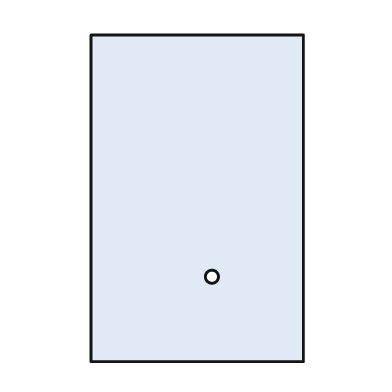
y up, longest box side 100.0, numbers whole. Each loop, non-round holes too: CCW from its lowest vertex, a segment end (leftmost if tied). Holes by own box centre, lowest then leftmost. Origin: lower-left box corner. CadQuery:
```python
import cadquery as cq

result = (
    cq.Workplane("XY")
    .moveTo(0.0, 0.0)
    .lineTo(65.0, 0.0)
    .lineTo(65.0, 100.0)
    .lineTo(0.0, 100.0)
    .close()
    .moveTo(37.0, 26.0)
    .circle(2.0)
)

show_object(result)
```